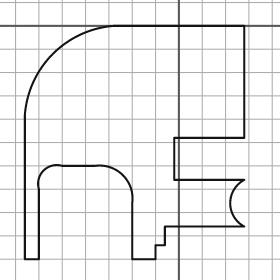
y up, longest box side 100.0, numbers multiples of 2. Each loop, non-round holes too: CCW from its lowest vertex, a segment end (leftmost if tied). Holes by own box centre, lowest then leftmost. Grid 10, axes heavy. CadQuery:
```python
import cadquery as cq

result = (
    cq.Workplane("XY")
    .moveTo(-66.0, -100.0)
    .lineTo(-60.0, -100.0)
    .lineTo(-60.0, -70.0)
    .threePointArc((-58.0, -62.0), (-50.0, -60.0))
    .lineTo(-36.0, -60.0)
    .threePointArc((-24.0, -64.0), (-20.0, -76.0))
    .lineTo(-20.0, -100.0)
    .lineTo(-10.0, -100.0)
    .lineTo(-10.0, -94.0)
    .lineTo(-6.0, -94.0)
    .lineTo(-6.0, -86.0)
    .lineTo(28.0, -86.0)
    .threePointArc((22.0, -76.0), (28.0, -66.0))
    .lineTo(-2.0, -66.0)
    .lineTo(-2.0, -48.0)
    .lineTo(28.0, -48.0)
    .lineTo(28.0, 0.0)
    .lineTo(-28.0, 0.0)
    .threePointArc((-54.0, -12.0), (-66.0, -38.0))
    .close()
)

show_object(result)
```